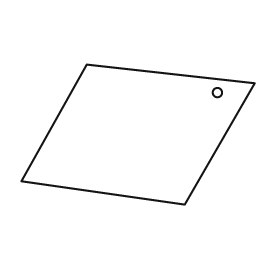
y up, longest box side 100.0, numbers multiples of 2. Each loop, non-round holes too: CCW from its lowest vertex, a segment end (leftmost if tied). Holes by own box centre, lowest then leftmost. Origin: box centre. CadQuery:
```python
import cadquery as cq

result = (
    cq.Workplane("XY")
    .moveTo(20.0, -30.0)
    .lineTo(50.0, 22.0)
    .lineTo(-22.0, 30.0)
    .lineTo(-50.0, -20.0)
    .close()
    .moveTo(34.0, 18.0)
    .circle(2.0)
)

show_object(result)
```